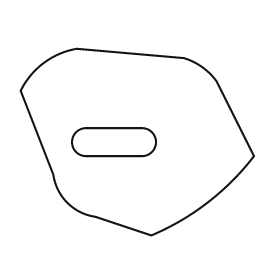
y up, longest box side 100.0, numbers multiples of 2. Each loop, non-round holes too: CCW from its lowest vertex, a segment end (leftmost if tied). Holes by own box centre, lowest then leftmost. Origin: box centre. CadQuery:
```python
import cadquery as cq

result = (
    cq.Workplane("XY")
    .moveTo(6.0, -40.0)
    .threePointArc((30.0, -26.0), (50.0, -6.0))
    .lineTo(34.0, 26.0)
    .threePointArc((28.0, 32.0), (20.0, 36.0))
    .lineTo(-26.0, 40.0)
    .threePointArc((-40.0, 34.0), (-50.0, 22.0))
    .lineTo(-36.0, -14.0)
    .threePointArc((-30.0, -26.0), (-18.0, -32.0))
    .close()
    .moveTo(-22.0, -6.0)
    .lineTo(2.0, -6.0)
    .threePointArc((8.0, 0.0), (2.0, 6.0))
    .lineTo(-22.0, 6.0)
    .threePointArc((-28.0, 0.0), (-22.0, -6.0))
    .close()
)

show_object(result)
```